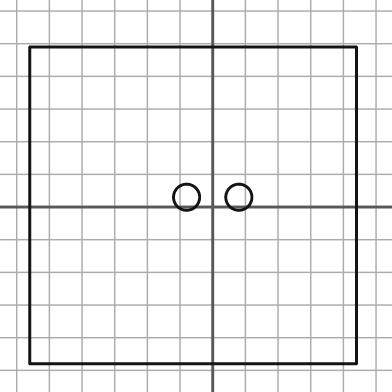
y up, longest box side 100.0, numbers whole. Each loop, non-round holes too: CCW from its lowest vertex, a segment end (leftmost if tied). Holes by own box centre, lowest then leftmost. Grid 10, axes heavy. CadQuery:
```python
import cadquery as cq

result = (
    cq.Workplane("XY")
    .moveTo(-56.0, -48.0)
    .lineTo(44.0, -48.0)
    .lineTo(44.0, 49.0)
    .lineTo(-56.0, 49.0)
    .close()
    .moveTo(-8.0, 3.0)
    .circle(4.0)
    .moveTo(8.0, 3.0)
    .circle(4.0)
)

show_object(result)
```